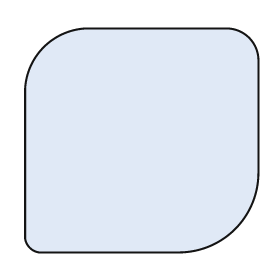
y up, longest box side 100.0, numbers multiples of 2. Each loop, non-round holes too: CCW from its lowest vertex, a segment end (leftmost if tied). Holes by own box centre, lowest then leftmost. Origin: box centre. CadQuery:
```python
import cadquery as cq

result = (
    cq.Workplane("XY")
    .moveTo(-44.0, -48.0)
    .lineTo(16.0, -48.0)
    .threePointArc((40.0, -38.0), (50.0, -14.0))
    .lineTo(50.0, 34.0)
    .threePointArc((46.0, 44.0), (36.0, 48.0))
    .lineTo(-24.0, 48.0)
    .threePointArc((-42.0, 40.0), (-50.0, 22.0))
    .lineTo(-50.0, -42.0)
    .threePointArc((-48.0, -46.0), (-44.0, -48.0))
    .close()
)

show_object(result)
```